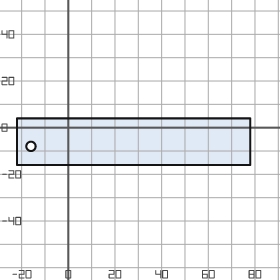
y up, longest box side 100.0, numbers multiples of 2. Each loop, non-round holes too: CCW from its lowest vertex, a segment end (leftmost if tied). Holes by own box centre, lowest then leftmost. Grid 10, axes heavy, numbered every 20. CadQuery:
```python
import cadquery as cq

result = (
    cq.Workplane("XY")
    .moveTo(-22.0, -16.0)
    .lineTo(78.0, -16.0)
    .lineTo(78.0, 4.0)
    .lineTo(-22.0, 4.0)
    .close()
    .moveTo(-16.0, -8.0)
    .circle(2.0)
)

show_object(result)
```